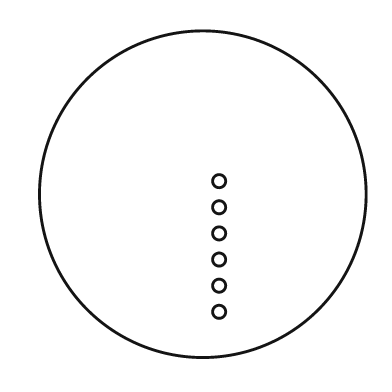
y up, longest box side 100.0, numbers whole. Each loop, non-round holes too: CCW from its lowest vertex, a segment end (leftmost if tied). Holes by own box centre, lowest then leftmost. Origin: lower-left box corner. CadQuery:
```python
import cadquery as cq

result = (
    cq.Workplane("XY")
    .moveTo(50.0, 50.0)
    .circle(50.0)
    .moveTo(55.0, 14.0)
    .circle(2.0)
    .moveTo(55.0, 22.0)
    .circle(2.0)
    .moveTo(55.0, 30.0)
    .circle(2.0)
    .moveTo(55.0, 38.0)
    .circle(2.0)
    .moveTo(55.0, 46.0)
    .circle(2.0)
    .moveTo(55.0, 54.0)
    .circle(2.0)
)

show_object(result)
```